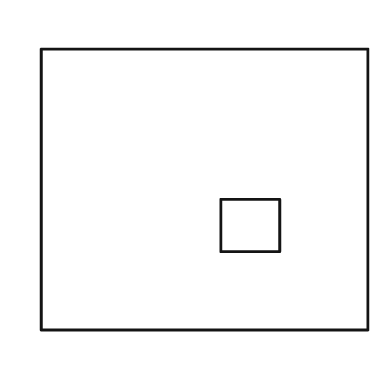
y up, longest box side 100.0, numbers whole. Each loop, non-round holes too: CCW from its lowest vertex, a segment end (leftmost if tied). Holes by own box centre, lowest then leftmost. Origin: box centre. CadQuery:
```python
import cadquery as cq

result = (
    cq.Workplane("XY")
    .moveTo(-50.0, -43.0)
    .lineTo(50.0, -43.0)
    .lineTo(50.0, 43.0)
    .lineTo(-50.0, 43.0)
    .close()
    .moveTo(5.0, -19.0)
    .lineTo(23.0, -19.0)
    .lineTo(23.0, -3.0)
    .lineTo(5.0, -3.0)
    .close()
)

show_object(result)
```